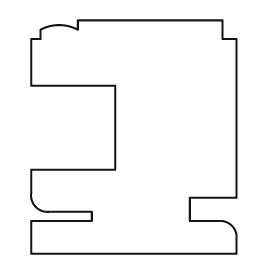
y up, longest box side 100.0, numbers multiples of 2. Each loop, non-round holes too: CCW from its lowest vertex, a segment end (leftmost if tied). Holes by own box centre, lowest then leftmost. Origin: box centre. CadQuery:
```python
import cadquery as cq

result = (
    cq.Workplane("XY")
    .moveTo(-44.0, -50.0)
    .lineTo(44.0, -50.0)
    .lineTo(44.0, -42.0)
    .threePointArc((42.0, -38.0), (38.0, -36.0))
    .lineTo(24.0, -36.0)
    .lineTo(24.0, -26.0)
    .lineTo(44.0, -26.0)
    .lineTo(44.0, 42.0)
    .lineTo(38.0, 42.0)
    .lineTo(38.0, 50.0)
    .lineTo(-24.0, 50.0)
    .lineTo(-24.0, 46.0)
    .threePointArc((-32.0, 48.0), (-40.0, 46.0))
    .lineTo(-40.0, 42.0)
    .lineTo(-44.0, 42.0)
    .lineTo(-44.0, 22.0)
    .lineTo(-8.0, 22.0)
    .lineTo(-8.0, -14.0)
    .lineTo(-44.0, -14.0)
    .lineTo(-44.0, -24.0)
    .threePointArc((-42.0, -30.0), (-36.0, -32.0))
    .lineTo(-18.0, -32.0)
    .lineTo(-18.0, -36.0)
    .lineTo(-44.0, -36.0)
    .close()
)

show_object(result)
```